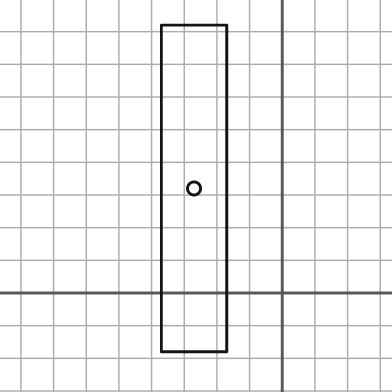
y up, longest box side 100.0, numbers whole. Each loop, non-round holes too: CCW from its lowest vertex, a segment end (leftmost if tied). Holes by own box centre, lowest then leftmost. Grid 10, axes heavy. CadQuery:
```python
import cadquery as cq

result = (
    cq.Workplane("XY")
    .moveTo(-37.0, -18.0)
    .lineTo(-17.0, -18.0)
    .lineTo(-17.0, 82.0)
    .lineTo(-37.0, 82.0)
    .close()
    .moveTo(-27.0, 32.0)
    .circle(2.0)
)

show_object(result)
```